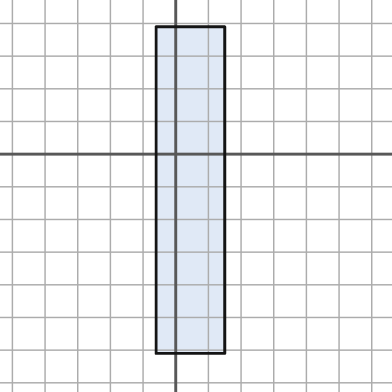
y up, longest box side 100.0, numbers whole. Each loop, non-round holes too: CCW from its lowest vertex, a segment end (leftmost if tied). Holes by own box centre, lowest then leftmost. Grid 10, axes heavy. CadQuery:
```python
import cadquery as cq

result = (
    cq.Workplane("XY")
    .moveTo(-6.0, -61.0)
    .lineTo(15.0, -61.0)
    .lineTo(15.0, 39.0)
    .lineTo(-6.0, 39.0)
    .close()
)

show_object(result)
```